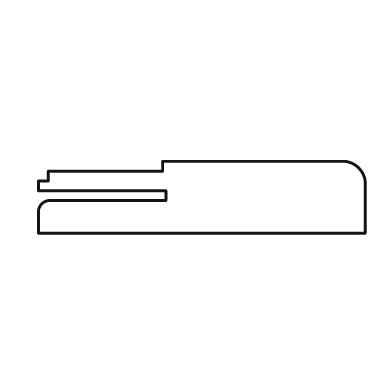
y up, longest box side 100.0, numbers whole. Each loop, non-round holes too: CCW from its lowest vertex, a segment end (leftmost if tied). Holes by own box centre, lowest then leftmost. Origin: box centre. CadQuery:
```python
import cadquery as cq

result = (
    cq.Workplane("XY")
    .moveTo(-50.0, -11.0)
    .lineTo(50.0, -11.0)
    .lineTo(50.0, 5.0)
    .threePointArc((48.0, 9.0), (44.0, 11.0))
    .lineTo(-12.0, 11.0)
    .lineTo(-12.0, 8.0)
    .lineTo(-47.0, 8.0)
    .lineTo(-47.0, 5.0)
    .lineTo(-50.0, 5.0)
    .lineTo(-50.0, 2.0)
    .lineTo(-11.0, 2.0)
    .lineTo(-11.0, -1.0)
    .lineTo(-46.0, -1.0)
    .threePointArc((-49.0, -2.0), (-50.0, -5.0))
    .close()
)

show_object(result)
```